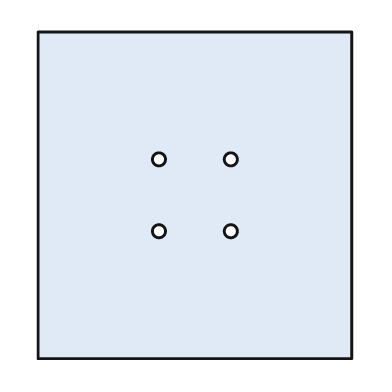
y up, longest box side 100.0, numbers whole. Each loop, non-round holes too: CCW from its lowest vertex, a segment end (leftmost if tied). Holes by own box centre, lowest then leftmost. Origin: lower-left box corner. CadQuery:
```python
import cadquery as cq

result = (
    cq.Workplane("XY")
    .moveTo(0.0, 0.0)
    .lineTo(96.0, 0.0)
    .lineTo(96.0, 100.0)
    .lineTo(0.0, 100.0)
    .close()
    .moveTo(37.0, 39.0)
    .circle(2.0)
    .moveTo(59.0, 39.0)
    .circle(2.0)
    .moveTo(37.0, 61.0)
    .circle(2.0)
    .moveTo(59.0, 61.0)
    .circle(2.0)
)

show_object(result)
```